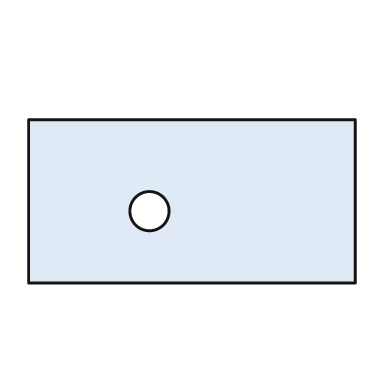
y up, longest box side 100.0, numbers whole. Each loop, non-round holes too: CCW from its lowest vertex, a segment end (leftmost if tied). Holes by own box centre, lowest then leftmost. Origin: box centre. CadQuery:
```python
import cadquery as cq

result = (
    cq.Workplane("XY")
    .moveTo(-50.0, -25.0)
    .lineTo(50.0, -25.0)
    .lineTo(50.0, 25.0)
    .lineTo(-50.0, 25.0)
    .close()
    .moveTo(-13.0, -3.0)
    .circle(6.0)
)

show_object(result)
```